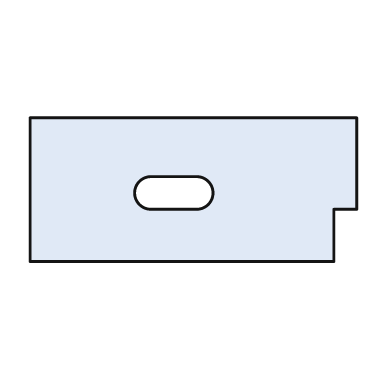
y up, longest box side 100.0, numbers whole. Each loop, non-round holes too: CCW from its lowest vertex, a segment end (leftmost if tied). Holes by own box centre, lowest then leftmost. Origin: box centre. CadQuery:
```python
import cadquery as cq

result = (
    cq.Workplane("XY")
    .moveTo(-50.0, -22.0)
    .lineTo(43.0, -22.0)
    .lineTo(43.0, -6.0)
    .lineTo(50.0, -6.0)
    .lineTo(50.0, 22.0)
    .lineTo(-50.0, 22.0)
    .close()
    .moveTo(-13.0, -6.0)
    .lineTo(1.0, -6.0)
    .threePointArc((6.0, -1.0), (1.0, 4.0))
    .lineTo(-13.0, 4.0)
    .threePointArc((-18.0, -1.0), (-13.0, -6.0))
    .close()
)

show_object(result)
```